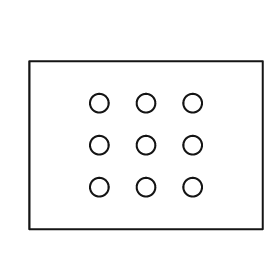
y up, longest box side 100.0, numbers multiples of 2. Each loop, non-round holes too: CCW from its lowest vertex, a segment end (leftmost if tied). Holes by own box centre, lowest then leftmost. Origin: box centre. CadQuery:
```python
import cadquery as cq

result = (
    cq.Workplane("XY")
    .moveTo(-50.0, -36.0)
    .lineTo(50.0, -36.0)
    .lineTo(50.0, 36.0)
    .lineTo(-50.0, 36.0)
    .close()
    .moveTo(-20.0, -18.0)
    .circle(4.0)
    .moveTo(0.0, -18.0)
    .circle(4.0)
    .moveTo(20.0, -18.0)
    .circle(4.0)
    .moveTo(-20.0, 0.0)
    .circle(4.0)
    .moveTo(0.0, 0.0)
    .circle(4.0)
    .moveTo(20.0, 0.0)
    .circle(4.0)
    .moveTo(-20.0, 18.0)
    .circle(4.0)
    .moveTo(0.0, 18.0)
    .circle(4.0)
    .moveTo(20.0, 18.0)
    .circle(4.0)
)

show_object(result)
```